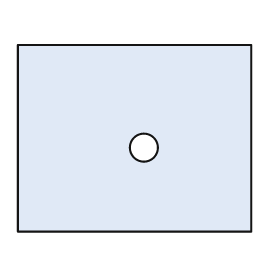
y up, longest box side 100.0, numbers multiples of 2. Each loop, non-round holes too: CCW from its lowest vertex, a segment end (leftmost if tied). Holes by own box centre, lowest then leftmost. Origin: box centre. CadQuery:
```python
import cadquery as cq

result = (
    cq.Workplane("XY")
    .moveTo(-50.0, -40.0)
    .lineTo(50.0, -40.0)
    .lineTo(50.0, 40.0)
    .lineTo(-50.0, 40.0)
    .close()
    .moveTo(4.0, -4.0)
    .circle(6.0)
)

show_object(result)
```